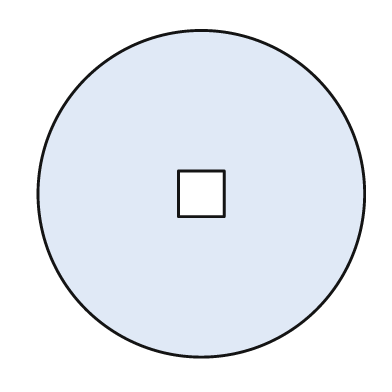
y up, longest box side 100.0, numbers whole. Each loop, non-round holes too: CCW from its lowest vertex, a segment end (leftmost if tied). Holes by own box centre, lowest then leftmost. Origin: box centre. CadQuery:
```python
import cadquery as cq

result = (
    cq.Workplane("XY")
    .moveTo(0.0, 0.0)
    .circle(50.0)
    .moveTo(-7.0, -7.0)
    .lineTo(7.0, -7.0)
    .lineTo(7.0, 7.0)
    .lineTo(-7.0, 7.0)
    .close()
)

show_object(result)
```